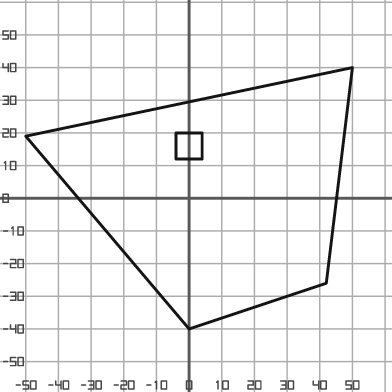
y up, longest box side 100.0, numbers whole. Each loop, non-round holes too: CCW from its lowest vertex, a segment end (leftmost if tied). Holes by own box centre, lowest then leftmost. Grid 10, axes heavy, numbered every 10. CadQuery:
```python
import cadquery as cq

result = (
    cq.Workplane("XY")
    .moveTo(0.0, -40.0)
    .lineTo(42.0, -26.0)
    .lineTo(50.0, 40.0)
    .lineTo(-50.0, 19.0)
    .close()
    .moveTo(-4.0, 12.0)
    .lineTo(4.0, 12.0)
    .lineTo(4.0, 20.0)
    .lineTo(-4.0, 20.0)
    .close()
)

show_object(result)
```